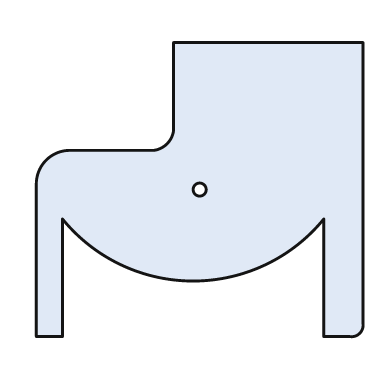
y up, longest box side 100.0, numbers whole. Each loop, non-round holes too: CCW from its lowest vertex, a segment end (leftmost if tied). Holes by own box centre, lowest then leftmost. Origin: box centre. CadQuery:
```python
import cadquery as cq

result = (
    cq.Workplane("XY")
    .moveTo(-50.0, -45.0)
    .lineTo(-42.0, -45.0)
    .lineTo(-42.0, -9.0)
    .threePointArc((-2.0, -28.0), (38.0, -9.0))
    .lineTo(38.0, -45.0)
    .lineTo(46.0, -45.0)
    .threePointArc((49.0, -44.0), (50.0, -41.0))
    .lineTo(50.0, 45.0)
    .lineTo(-8.0, 45.0)
    .lineTo(-8.0, 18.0)
    .threePointArc((-10.0, 14.0), (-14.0, 12.0))
    .lineTo(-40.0, 12.0)
    .threePointArc((-47.0, 9.0), (-50.0, 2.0))
    .close()
    .moveTo(0.0, 0.0)
    .circle(2.0)
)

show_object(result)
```